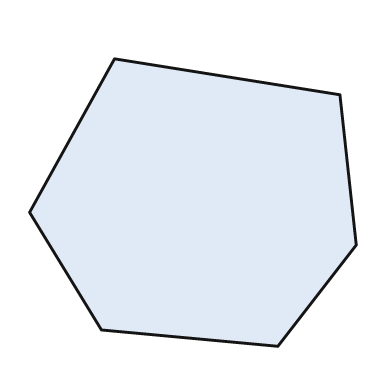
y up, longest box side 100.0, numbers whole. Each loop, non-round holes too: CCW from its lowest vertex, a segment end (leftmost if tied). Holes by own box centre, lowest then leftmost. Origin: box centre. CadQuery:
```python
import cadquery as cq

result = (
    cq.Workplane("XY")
    .moveTo(26.0, -44.0)
    .lineTo(50.0, -13.0)
    .lineTo(45.0, 33.0)
    .lineTo(-24.0, 44.0)
    .lineTo(-50.0, -3.0)
    .lineTo(-28.0, -39.0)
    .close()
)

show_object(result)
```